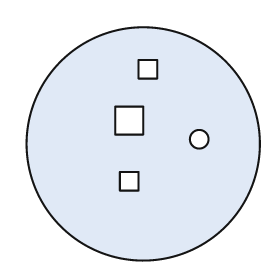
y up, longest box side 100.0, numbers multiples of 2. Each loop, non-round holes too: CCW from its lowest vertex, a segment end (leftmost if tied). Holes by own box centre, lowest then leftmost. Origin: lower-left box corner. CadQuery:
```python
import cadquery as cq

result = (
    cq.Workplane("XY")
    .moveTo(50.0, 50.0)
    .circle(50.0)
    .moveTo(40.0, 30.0)
    .lineTo(48.0, 30.0)
    .lineTo(48.0, 38.0)
    .lineTo(40.0, 38.0)
    .close()
    .moveTo(74.0, 52.0)
    .circle(4.0)
    .moveTo(38.0, 54.0)
    .lineTo(50.0, 54.0)
    .lineTo(50.0, 66.0)
    .lineTo(38.0, 66.0)
    .close()
    .moveTo(48.0, 78.0)
    .lineTo(56.0, 78.0)
    .lineTo(56.0, 86.0)
    .lineTo(48.0, 86.0)
    .close()
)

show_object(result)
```